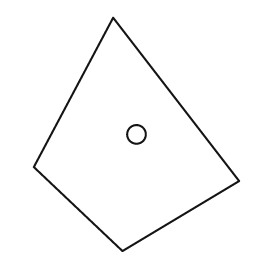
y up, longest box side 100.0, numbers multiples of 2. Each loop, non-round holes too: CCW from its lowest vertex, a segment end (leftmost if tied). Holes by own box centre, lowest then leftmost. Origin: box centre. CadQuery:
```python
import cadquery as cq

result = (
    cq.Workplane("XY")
    .moveTo(-6.0, -50.0)
    .lineTo(44.0, -20.0)
    .lineTo(-10.0, 50.0)
    .lineTo(-44.0, -14.0)
    .close()
    .moveTo(0.0, 0.0)
    .circle(4.0)
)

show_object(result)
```